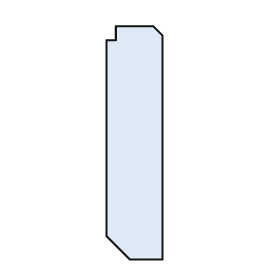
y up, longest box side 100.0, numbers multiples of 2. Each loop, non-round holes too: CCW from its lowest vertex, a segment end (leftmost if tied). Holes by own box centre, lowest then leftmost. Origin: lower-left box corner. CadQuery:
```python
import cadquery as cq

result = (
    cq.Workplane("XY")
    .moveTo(10.0, 0.0)
    .lineTo(24.0, 0.0)
    .lineTo(24.0, 96.0)
    .lineTo(20.0, 100.0)
    .lineTo(4.0, 100.0)
    .lineTo(4.0, 94.0)
    .lineTo(0.0, 94.0)
    .lineTo(0.0, 10.0)
    .close()
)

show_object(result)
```